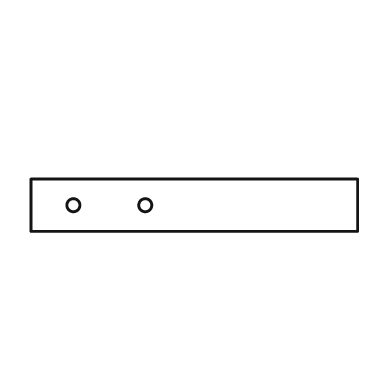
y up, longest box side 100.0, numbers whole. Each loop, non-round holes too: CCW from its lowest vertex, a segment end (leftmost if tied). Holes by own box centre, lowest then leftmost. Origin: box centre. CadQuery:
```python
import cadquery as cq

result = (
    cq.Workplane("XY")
    .moveTo(-50.0, -8.0)
    .lineTo(50.0, -8.0)
    .lineTo(50.0, 8.0)
    .lineTo(-50.0, 8.0)
    .close()
    .moveTo(-37.0, 0.0)
    .circle(2.0)
    .moveTo(-15.0, 0.0)
    .circle(2.0)
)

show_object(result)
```